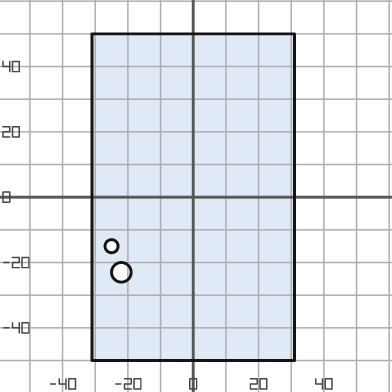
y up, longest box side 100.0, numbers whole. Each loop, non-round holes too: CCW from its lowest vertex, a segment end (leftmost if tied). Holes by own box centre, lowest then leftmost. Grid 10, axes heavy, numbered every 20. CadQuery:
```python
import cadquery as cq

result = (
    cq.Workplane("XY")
    .moveTo(-31.0, -50.0)
    .lineTo(31.0, -50.0)
    .lineTo(31.0, 50.0)
    .lineTo(-31.0, 50.0)
    .close()
    .moveTo(-22.0, -23.0)
    .circle(3.0)
    .moveTo(-25.0, -15.0)
    .circle(2.0)
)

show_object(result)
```